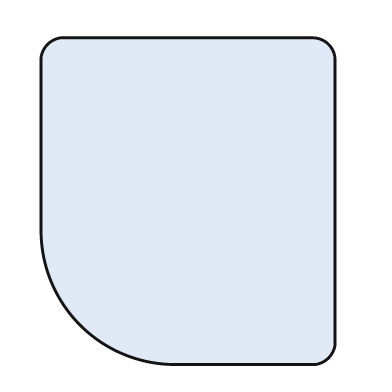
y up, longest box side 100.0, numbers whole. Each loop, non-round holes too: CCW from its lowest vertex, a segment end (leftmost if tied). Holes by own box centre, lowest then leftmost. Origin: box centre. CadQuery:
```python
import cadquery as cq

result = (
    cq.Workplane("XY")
    .moveTo(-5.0, -50.0)
    .lineTo(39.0, -50.0)
    .threePointArc((43.0, -48.0), (45.0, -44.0))
    .lineTo(45.0, 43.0)
    .threePointArc((43.0, 48.0), (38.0, 50.0))
    .lineTo(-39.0, 50.0)
    .threePointArc((-43.0, 48.0), (-45.0, 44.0))
    .lineTo(-45.0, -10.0)
    .threePointArc((-33.0, -38.0), (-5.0, -50.0))
    .close()
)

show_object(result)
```